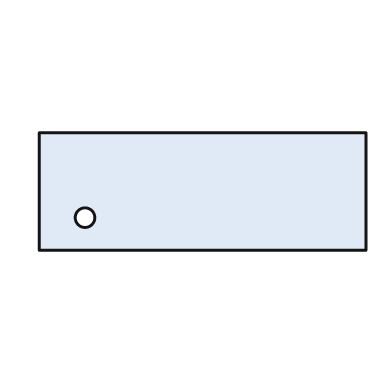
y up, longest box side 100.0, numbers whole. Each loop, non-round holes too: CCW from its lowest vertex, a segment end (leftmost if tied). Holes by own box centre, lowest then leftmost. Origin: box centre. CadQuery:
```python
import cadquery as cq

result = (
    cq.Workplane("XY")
    .moveTo(-50.0, -18.0)
    .lineTo(50.0, -18.0)
    .lineTo(50.0, 18.0)
    .lineTo(-50.0, 18.0)
    .close()
    .moveTo(-36.0, -8.0)
    .circle(3.0)
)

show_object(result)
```